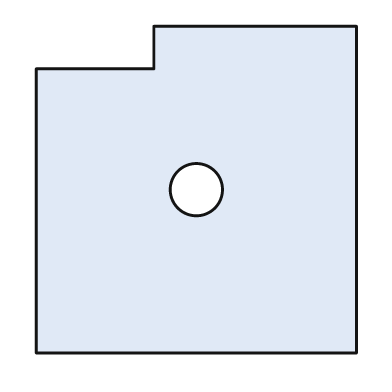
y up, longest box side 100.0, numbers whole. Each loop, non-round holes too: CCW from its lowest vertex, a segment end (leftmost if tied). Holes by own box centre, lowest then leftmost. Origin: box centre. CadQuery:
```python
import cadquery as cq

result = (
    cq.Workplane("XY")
    .moveTo(-49.0, -50.0)
    .lineTo(49.0, -50.0)
    .lineTo(49.0, 50.0)
    .lineTo(-13.0, 50.0)
    .lineTo(-13.0, 37.0)
    .lineTo(-49.0, 37.0)
    .close()
    .moveTo(0.0, 0.0)
    .circle(8.0)
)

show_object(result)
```